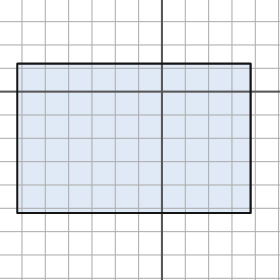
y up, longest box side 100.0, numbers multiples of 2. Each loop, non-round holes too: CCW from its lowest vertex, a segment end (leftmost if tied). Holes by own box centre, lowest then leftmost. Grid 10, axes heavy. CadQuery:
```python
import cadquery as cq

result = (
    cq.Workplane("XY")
    .moveTo(-62.0, -52.0)
    .lineTo(38.0, -52.0)
    .lineTo(38.0, 12.0)
    .lineTo(-62.0, 12.0)
    .close()
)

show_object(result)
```